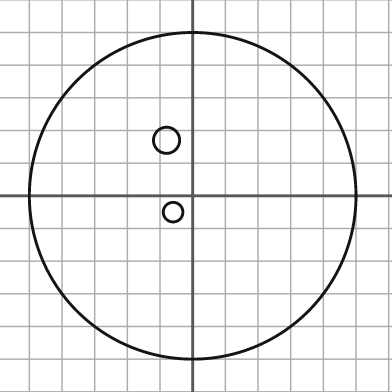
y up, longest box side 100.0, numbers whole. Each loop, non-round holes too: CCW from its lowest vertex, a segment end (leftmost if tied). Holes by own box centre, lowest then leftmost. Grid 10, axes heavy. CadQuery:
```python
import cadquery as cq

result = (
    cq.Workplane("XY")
    .moveTo(0.0, 0.0)
    .circle(50.0)
    .moveTo(-6.0, -5.0)
    .circle(3.0)
    .moveTo(-8.0, 17.0)
    .circle(4.0)
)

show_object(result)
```